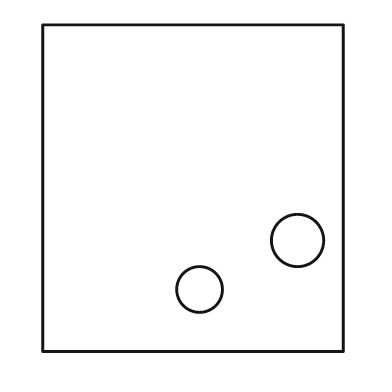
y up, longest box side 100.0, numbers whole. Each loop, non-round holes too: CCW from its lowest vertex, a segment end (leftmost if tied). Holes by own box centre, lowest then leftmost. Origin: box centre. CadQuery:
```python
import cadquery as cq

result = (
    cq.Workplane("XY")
    .moveTo(-46.0, -50.0)
    .lineTo(46.0, -50.0)
    .lineTo(46.0, 50.0)
    .lineTo(-46.0, 50.0)
    .close()
    .moveTo(2.0, -31.0)
    .circle(7.0)
    .moveTo(32.0, -16.0)
    .circle(8.0)
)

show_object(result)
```